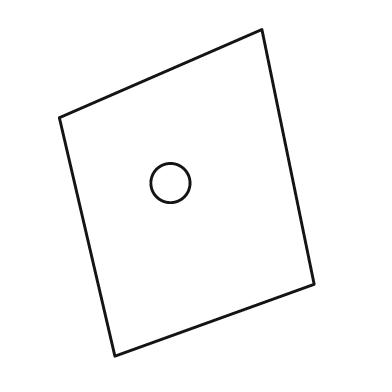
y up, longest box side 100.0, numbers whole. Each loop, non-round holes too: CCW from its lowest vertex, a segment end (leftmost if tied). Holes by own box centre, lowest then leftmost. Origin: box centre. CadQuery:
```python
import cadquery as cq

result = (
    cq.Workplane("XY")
    .moveTo(-22.0, -50.0)
    .lineTo(39.0, -28.0)
    .lineTo(23.0, 50.0)
    .lineTo(-39.0, 23.0)
    .close()
    .moveTo(-5.0, 3.0)
    .circle(6.0)
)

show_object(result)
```